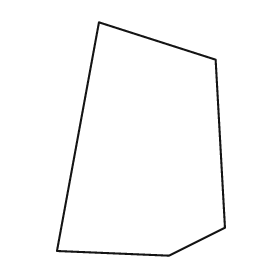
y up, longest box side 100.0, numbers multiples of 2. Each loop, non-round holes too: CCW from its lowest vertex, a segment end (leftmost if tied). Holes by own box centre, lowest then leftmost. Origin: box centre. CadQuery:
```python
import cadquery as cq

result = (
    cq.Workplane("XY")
    .moveTo(12.0, -50.0)
    .lineTo(36.0, -38.0)
    .lineTo(32.0, 34.0)
    .lineTo(-18.0, 50.0)
    .lineTo(-36.0, -48.0)
    .close()
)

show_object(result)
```